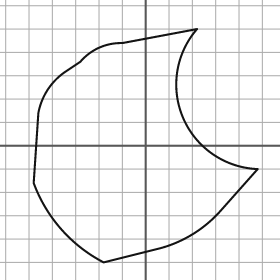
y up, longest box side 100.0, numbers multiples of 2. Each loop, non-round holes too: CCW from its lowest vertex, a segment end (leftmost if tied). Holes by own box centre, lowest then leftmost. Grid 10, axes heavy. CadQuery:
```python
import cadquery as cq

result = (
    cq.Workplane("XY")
    .moveTo(-18.0, -50.0)
    .lineTo(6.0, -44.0)
    .threePointArc((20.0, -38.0), (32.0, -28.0))
    .lineTo(48.0, -10.0)
    .threePointArc((16.0, 12.0), (22.0, 50.0))
    .lineTo(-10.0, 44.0)
    .threePointArc((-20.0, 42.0), (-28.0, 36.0))
    .lineTo(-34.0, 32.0)
    .threePointArc((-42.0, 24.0), (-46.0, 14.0))
    .lineTo(-48.0, -16.0)
    .threePointArc((-36.0, -36.0), (-18.0, -50.0))
    .close()
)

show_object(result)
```